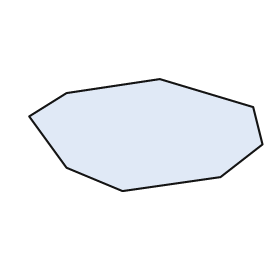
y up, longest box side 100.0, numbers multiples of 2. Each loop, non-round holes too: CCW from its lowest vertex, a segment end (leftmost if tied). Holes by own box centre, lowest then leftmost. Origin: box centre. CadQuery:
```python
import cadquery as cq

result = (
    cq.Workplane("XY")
    .moveTo(-10.0, -24.0)
    .lineTo(32.0, -18.0)
    .lineTo(50.0, -4.0)
    .lineTo(46.0, 12.0)
    .lineTo(6.0, 24.0)
    .lineTo(-34.0, 18.0)
    .lineTo(-50.0, 8.0)
    .lineTo(-34.0, -14.0)
    .close()
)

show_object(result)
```